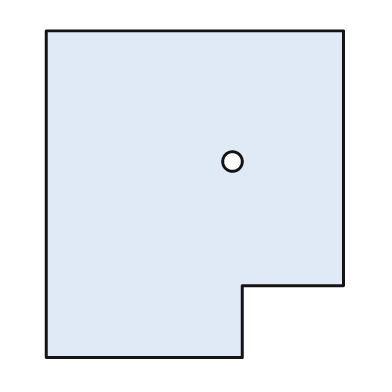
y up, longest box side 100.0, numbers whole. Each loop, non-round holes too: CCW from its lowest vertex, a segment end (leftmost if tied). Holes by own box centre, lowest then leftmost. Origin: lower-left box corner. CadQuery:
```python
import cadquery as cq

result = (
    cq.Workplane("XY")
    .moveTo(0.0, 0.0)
    .lineTo(60.0, 0.0)
    .lineTo(60.0, 22.0)
    .lineTo(91.0, 22.0)
    .lineTo(91.0, 100.0)
    .lineTo(0.0, 100.0)
    .close()
    .moveTo(57.0, 60.0)
    .circle(3.0)
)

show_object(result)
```